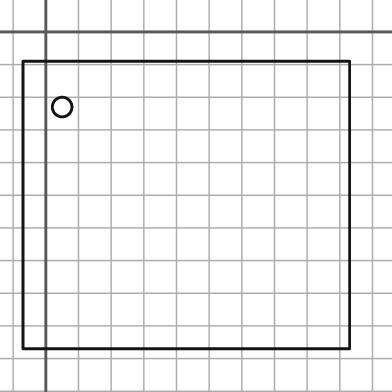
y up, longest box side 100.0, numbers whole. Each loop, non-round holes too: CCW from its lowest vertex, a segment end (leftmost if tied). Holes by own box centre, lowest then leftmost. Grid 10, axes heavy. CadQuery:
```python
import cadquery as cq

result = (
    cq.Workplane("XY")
    .moveTo(-7.0, -97.0)
    .lineTo(93.0, -97.0)
    .lineTo(93.0, -9.0)
    .lineTo(-7.0, -9.0)
    .close()
    .moveTo(5.0, -23.0)
    .circle(3.0)
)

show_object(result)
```